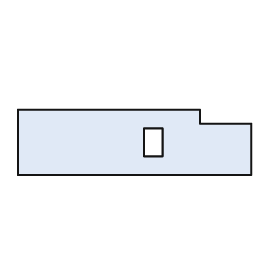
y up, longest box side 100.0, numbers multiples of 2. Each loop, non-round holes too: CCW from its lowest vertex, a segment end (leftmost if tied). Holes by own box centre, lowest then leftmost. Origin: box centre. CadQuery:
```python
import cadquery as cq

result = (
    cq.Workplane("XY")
    .moveTo(-50.0, -14.0)
    .lineTo(50.0, -14.0)
    .lineTo(50.0, 8.0)
    .lineTo(28.0, 8.0)
    .lineTo(28.0, 14.0)
    .lineTo(-50.0, 14.0)
    .close()
    .moveTo(4.0, -6.0)
    .lineTo(12.0, -6.0)
    .lineTo(12.0, 6.0)
    .lineTo(4.0, 6.0)
    .close()
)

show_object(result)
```